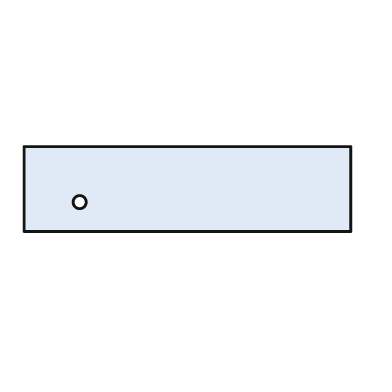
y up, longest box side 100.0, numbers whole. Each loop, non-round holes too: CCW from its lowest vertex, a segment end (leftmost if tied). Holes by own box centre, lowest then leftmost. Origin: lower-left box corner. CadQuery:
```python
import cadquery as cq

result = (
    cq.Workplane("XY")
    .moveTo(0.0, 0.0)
    .lineTo(100.0, 0.0)
    .lineTo(100.0, 26.0)
    .lineTo(0.0, 26.0)
    .close()
    .moveTo(17.0, 9.0)
    .circle(2.0)
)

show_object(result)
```